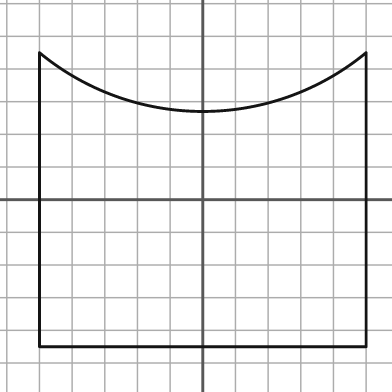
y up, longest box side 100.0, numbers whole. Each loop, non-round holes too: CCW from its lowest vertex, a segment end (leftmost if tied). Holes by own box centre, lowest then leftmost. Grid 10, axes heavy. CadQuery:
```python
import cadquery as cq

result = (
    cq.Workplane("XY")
    .moveTo(-50.0, -45.0)
    .lineTo(50.0, -45.0)
    .lineTo(50.0, 45.0)
    .threePointArc((0.0, 27.0), (-50.0, 45.0))
    .close()
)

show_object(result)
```